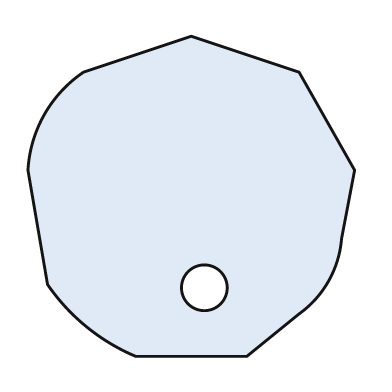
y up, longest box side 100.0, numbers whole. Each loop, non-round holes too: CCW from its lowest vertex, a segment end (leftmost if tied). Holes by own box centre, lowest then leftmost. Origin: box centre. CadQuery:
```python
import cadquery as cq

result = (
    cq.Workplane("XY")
    .moveTo(-17.0, -49.0)
    .lineTo(17.0, -49.0)
    .lineTo(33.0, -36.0)
    .threePointArc((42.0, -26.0), (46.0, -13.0))
    .lineTo(50.0, 8.0)
    .lineTo(33.0, 38.0)
    .lineTo(0.0, 49.0)
    .lineTo(-33.0, 38.0)
    .threePointArc((-45.0, 25.0), (-50.0, 8.0))
    .lineTo(-44.0, -27.0)
    .threePointArc((-32.0, -40.0), (-17.0, -49.0))
    .close()
    .moveTo(4.0, -28.0)
    .circle(7.0)
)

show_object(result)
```